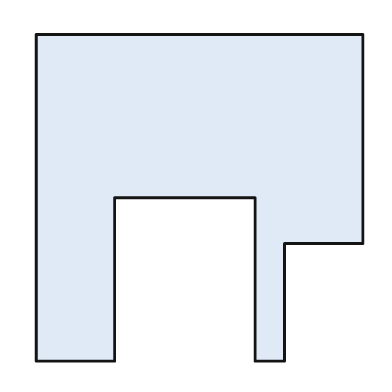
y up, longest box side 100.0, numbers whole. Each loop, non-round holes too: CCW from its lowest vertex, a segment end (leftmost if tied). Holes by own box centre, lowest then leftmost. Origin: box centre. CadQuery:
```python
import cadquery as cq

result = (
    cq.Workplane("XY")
    .moveTo(-50.0, -50.0)
    .lineTo(-26.0, -50.0)
    .lineTo(-26.0, 0.0)
    .lineTo(17.0, 0.0)
    .lineTo(17.0, -50.0)
    .lineTo(26.0, -50.0)
    .lineTo(26.0, -14.0)
    .lineTo(50.0, -14.0)
    .lineTo(50.0, 50.0)
    .lineTo(-50.0, 50.0)
    .close()
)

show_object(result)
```